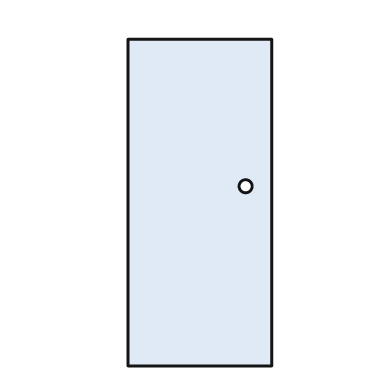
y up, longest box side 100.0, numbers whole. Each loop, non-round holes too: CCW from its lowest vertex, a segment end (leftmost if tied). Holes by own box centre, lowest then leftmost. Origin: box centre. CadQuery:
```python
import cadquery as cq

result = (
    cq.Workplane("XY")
    .moveTo(-22.0, -50.0)
    .lineTo(22.0, -50.0)
    .lineTo(22.0, 50.0)
    .lineTo(-22.0, 50.0)
    .close()
    .moveTo(14.0, 5.0)
    .circle(2.0)
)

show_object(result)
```